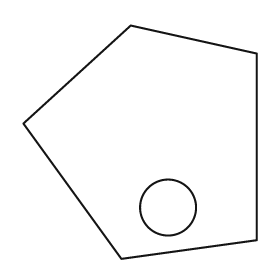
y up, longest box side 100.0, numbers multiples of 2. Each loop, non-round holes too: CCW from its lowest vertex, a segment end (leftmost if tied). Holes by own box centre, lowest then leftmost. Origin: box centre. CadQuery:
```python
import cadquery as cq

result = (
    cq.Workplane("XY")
    .moveTo(-8.0, -50.0)
    .lineTo(50.0, -42.0)
    .lineTo(50.0, 38.0)
    .lineTo(-4.0, 50.0)
    .lineTo(-50.0, 8.0)
    .close()
    .moveTo(12.0, -28.0)
    .circle(12.0)
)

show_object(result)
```